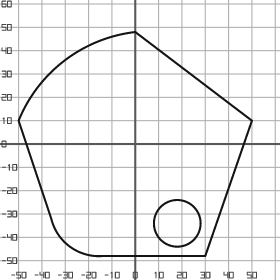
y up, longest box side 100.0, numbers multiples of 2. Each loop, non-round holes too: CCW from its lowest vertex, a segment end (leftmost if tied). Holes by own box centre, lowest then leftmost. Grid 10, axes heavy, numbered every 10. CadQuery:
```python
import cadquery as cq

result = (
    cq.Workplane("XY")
    .moveTo(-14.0, -48.0)
    .lineTo(30.0, -48.0)
    .lineTo(50.0, 10.0)
    .lineTo(0.0, 48.0)
    .threePointArc((-30.0, 36.0), (-50.0, 10.0))
    .lineTo(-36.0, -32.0)
    .threePointArc((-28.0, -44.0), (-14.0, -48.0))
    .close()
    .moveTo(18.0, -34.0)
    .circle(10.0)
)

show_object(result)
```